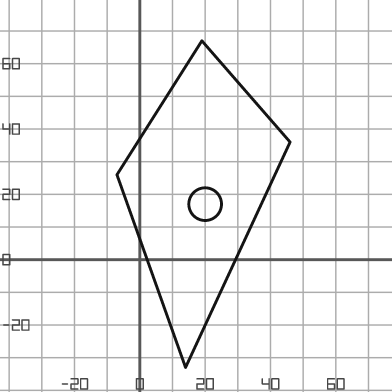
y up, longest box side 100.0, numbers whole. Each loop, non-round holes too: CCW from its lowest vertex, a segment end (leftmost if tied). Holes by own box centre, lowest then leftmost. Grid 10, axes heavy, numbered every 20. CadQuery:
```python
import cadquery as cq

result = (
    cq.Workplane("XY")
    .moveTo(14.0, -33.0)
    .lineTo(46.0, 36.0)
    .lineTo(19.0, 67.0)
    .lineTo(-7.0, 26.0)
    .close()
    .moveTo(20.0, 17.0)
    .circle(5.0)
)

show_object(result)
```